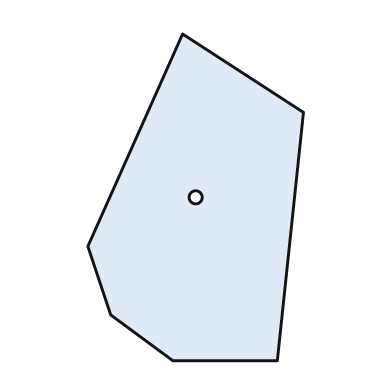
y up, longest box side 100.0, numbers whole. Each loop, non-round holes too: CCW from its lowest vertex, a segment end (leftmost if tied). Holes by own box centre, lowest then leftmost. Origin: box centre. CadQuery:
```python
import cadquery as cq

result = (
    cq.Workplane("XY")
    .moveTo(-7.0, -50.0)
    .lineTo(25.0, -50.0)
    .lineTo(33.0, 26.0)
    .lineTo(-4.0, 50.0)
    .lineTo(-33.0, -15.0)
    .lineTo(-26.0, -36.0)
    .close()
    .moveTo(0.0, 0.0)
    .circle(2.0)
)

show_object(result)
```